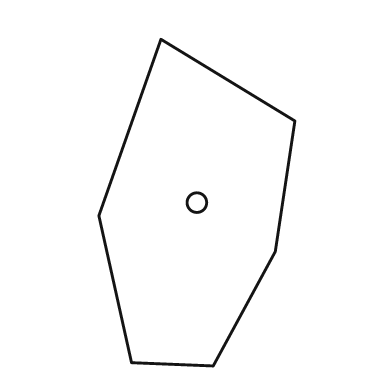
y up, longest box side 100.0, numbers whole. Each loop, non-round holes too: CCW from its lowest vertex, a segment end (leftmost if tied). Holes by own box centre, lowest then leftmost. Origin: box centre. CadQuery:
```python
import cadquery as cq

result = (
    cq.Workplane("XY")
    .moveTo(5.0, -50.0)
    .lineTo(24.0, -15.0)
    .lineTo(30.0, 25.0)
    .lineTo(-11.0, 50.0)
    .lineTo(-30.0, -4.0)
    .lineTo(-20.0, -49.0)
    .close()
    .moveTo(0.0, 0.0)
    .circle(3.0)
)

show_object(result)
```